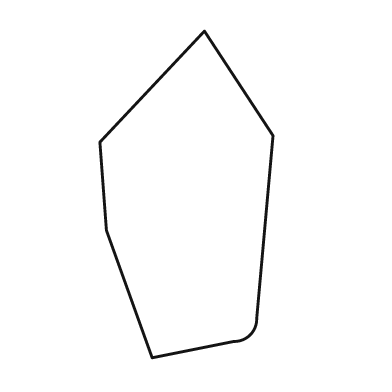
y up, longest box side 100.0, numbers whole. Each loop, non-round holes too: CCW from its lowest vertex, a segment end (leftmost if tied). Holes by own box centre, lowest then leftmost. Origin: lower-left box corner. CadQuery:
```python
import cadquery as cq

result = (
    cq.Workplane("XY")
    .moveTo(16.0, 0.0)
    .lineTo(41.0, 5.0)
    .threePointArc((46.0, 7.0), (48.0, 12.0))
    .lineTo(53.0, 68.0)
    .lineTo(32.0, 100.0)
    .lineTo(0.0, 66.0)
    .lineTo(2.0, 39.0)
    .close()
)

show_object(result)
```